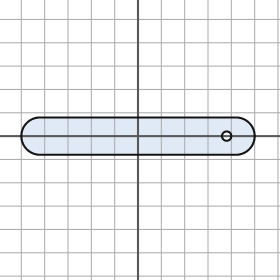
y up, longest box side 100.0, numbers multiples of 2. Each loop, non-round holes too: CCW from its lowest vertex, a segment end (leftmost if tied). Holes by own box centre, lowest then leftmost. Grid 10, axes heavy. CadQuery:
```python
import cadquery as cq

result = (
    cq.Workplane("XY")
    .moveTo(-42.0, -8.0)
    .lineTo(42.0, -8.0)
    .threePointArc((50.0, 0.0), (42.0, 8.0))
    .lineTo(-42.0, 8.0)
    .threePointArc((-50.0, 0.0), (-42.0, -8.0))
    .close()
    .moveTo(38.0, 0.0)
    .circle(2.0)
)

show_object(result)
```